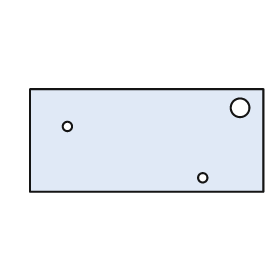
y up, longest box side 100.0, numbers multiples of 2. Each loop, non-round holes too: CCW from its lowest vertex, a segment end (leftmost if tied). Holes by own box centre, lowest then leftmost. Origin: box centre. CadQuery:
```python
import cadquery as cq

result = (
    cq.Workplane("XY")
    .moveTo(-50.0, -22.0)
    .lineTo(50.0, -22.0)
    .lineTo(50.0, 22.0)
    .lineTo(-50.0, 22.0)
    .close()
    .moveTo(24.0, -16.0)
    .circle(2.0)
    .moveTo(-34.0, 6.0)
    .circle(2.0)
    .moveTo(40.0, 14.0)
    .circle(4.0)
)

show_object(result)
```